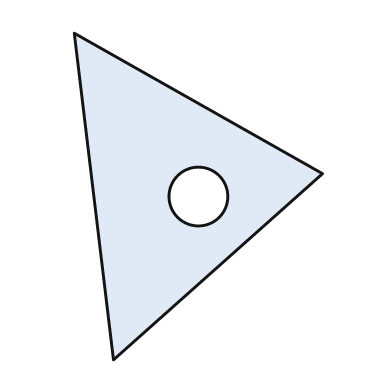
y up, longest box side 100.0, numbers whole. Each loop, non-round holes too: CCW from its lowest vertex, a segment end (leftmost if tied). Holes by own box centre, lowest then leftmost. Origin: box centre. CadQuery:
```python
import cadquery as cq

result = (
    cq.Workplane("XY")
    .moveTo(-26.0, -50.0)
    .lineTo(38.0, 7.0)
    .lineTo(-38.0, 50.0)
    .close()
    .moveTo(0.0, 0.0)
    .circle(9.0)
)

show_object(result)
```